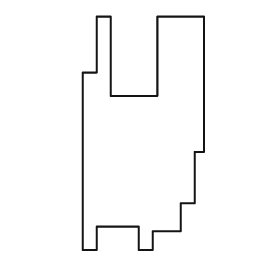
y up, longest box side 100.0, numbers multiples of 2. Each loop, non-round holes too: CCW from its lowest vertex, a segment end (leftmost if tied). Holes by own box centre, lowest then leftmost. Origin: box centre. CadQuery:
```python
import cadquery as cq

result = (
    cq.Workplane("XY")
    .moveTo(-26.0, -50.0)
    .lineTo(-20.0, -50.0)
    .lineTo(-20.0, -40.0)
    .lineTo(-2.0, -40.0)
    .lineTo(-2.0, -50.0)
    .lineTo(4.0, -50.0)
    .lineTo(4.0, -42.0)
    .lineTo(16.0, -42.0)
    .lineTo(16.0, -30.0)
    .lineTo(22.0, -30.0)
    .lineTo(22.0, -8.0)
    .lineTo(26.0, -8.0)
    .lineTo(26.0, 50.0)
    .lineTo(6.0, 50.0)
    .lineTo(6.0, 16.0)
    .lineTo(-14.0, 16.0)
    .lineTo(-14.0, 50.0)
    .lineTo(-20.0, 50.0)
    .lineTo(-20.0, 26.0)
    .lineTo(-26.0, 26.0)
    .close()
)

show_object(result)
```